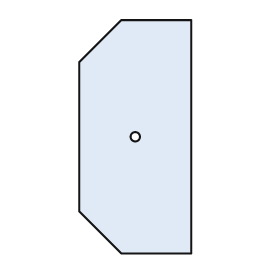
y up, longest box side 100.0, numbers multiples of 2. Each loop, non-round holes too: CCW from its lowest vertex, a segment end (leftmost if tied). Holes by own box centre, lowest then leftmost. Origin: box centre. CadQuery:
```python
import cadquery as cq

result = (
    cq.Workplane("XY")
    .moveTo(-6.0, -50.0)
    .lineTo(24.0, -50.0)
    .lineTo(24.0, 50.0)
    .lineTo(-6.0, 50.0)
    .lineTo(-24.0, 32.0)
    .lineTo(-24.0, -32.0)
    .close()
    .moveTo(0.0, 0.0)
    .circle(2.0)
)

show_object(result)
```